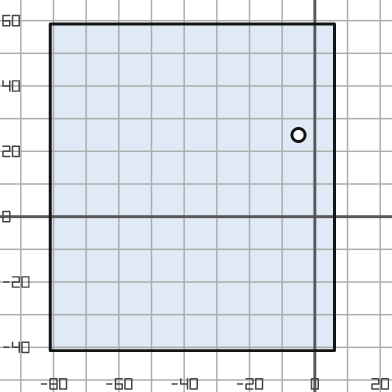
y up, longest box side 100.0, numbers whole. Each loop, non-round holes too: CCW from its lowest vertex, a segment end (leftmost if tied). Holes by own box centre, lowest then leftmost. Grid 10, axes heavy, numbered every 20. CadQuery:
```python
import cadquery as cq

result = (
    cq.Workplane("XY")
    .moveTo(-81.0, -41.0)
    .lineTo(6.0, -41.0)
    .lineTo(6.0, 59.0)
    .lineTo(-81.0, 59.0)
    .close()
    .moveTo(-5.0, 25.0)
    .circle(2.0)
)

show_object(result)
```